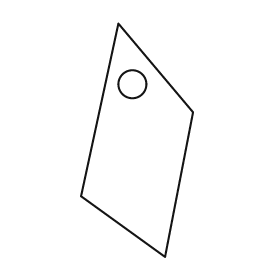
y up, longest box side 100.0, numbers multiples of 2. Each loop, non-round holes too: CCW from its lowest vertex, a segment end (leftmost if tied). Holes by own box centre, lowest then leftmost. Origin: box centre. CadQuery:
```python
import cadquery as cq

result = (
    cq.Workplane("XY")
    .moveTo(12.0, -50.0)
    .lineTo(24.0, 12.0)
    .lineTo(-8.0, 50.0)
    .lineTo(-24.0, -24.0)
    .close()
    .moveTo(-2.0, 24.0)
    .circle(6.0)
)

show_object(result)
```